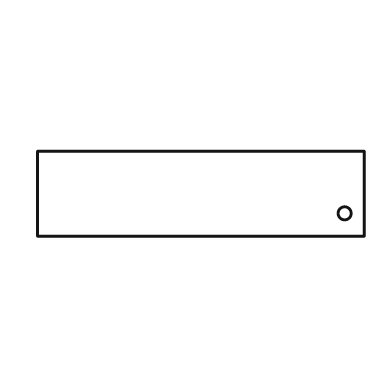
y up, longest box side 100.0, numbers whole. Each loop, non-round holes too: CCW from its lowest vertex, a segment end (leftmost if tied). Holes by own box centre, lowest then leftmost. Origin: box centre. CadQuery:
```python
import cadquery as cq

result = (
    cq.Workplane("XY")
    .moveTo(-50.0, -13.0)
    .lineTo(50.0, -13.0)
    .lineTo(50.0, 13.0)
    .lineTo(-50.0, 13.0)
    .close()
    .moveTo(44.0, -6.0)
    .circle(2.0)
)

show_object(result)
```